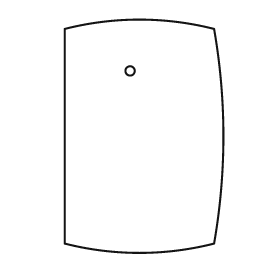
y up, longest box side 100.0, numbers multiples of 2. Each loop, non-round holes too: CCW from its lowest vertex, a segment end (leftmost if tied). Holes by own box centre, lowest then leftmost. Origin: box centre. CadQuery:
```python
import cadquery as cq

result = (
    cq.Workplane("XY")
    .moveTo(-34.0, -46.0)
    .threePointArc((-2.0, -50.0), (30.0, -46.0))
    .threePointArc((34.0, 0.0), (30.0, 46.0))
    .threePointArc((-2.0, 50.0), (-34.0, 46.0))
    .close()
    .moveTo(-6.0, 28.0)
    .circle(2.0)
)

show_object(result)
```